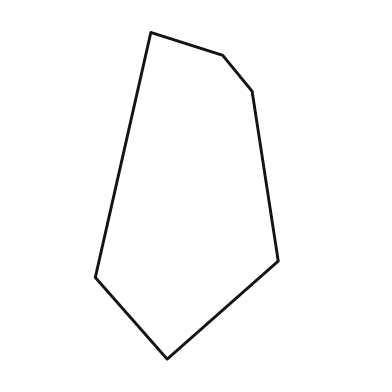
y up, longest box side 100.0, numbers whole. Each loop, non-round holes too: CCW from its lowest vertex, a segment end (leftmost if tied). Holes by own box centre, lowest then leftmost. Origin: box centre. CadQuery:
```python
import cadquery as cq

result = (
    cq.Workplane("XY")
    .moveTo(-6.0, -50.0)
    .lineTo(28.0, -20.0)
    .lineTo(20.0, 32.0)
    .lineTo(11.0, 43.0)
    .lineTo(-11.0, 50.0)
    .lineTo(-28.0, -25.0)
    .close()
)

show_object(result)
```